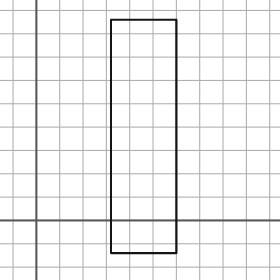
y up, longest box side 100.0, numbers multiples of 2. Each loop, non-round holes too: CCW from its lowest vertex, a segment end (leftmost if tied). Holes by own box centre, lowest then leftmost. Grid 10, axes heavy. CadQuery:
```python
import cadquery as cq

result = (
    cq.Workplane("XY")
    .moveTo(32.0, -14.0)
    .lineTo(60.0, -14.0)
    .lineTo(60.0, 86.0)
    .lineTo(32.0, 86.0)
    .close()
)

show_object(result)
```